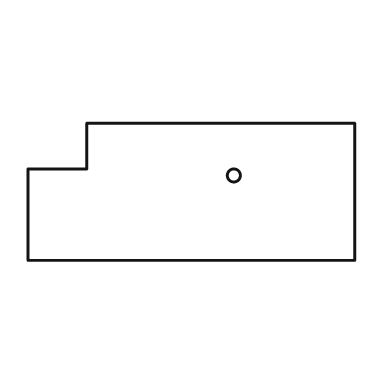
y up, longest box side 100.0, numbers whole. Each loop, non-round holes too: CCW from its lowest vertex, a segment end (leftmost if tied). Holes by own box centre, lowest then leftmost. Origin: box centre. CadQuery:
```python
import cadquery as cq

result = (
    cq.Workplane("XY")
    .moveTo(-50.0, -21.0)
    .lineTo(50.0, -21.0)
    .lineTo(50.0, 21.0)
    .lineTo(-32.0, 21.0)
    .lineTo(-32.0, 7.0)
    .lineTo(-50.0, 7.0)
    .close()
    .moveTo(13.0, 5.0)
    .circle(2.0)
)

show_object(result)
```